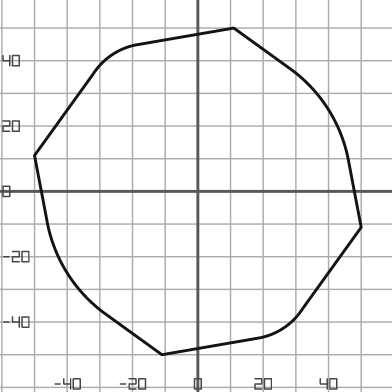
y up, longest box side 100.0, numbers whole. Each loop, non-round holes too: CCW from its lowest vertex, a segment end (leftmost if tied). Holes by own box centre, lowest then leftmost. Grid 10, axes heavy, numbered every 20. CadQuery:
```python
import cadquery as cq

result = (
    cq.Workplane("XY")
    .moveTo(-11.0, -50.0)
    .lineTo(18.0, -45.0)
    .threePointArc((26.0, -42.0), (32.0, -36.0))
    .lineTo(50.0, -11.0)
    .lineTo(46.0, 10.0)
    .threePointArc((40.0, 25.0), (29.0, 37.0))
    .lineTo(11.0, 50.0)
    .lineTo(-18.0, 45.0)
    .threePointArc((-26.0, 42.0), (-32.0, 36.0))
    .lineTo(-50.0, 11.0)
    .lineTo(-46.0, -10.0)
    .threePointArc((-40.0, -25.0), (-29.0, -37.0))
    .close()
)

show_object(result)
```